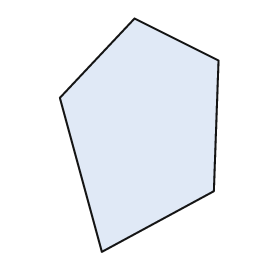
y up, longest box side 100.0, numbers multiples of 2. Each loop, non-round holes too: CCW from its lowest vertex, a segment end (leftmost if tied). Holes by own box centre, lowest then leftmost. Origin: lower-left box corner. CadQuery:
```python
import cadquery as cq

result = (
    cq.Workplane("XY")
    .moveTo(18.0, 0.0)
    .lineTo(66.0, 26.0)
    .lineTo(68.0, 82.0)
    .lineTo(32.0, 100.0)
    .lineTo(0.0, 66.0)
    .close()
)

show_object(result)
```